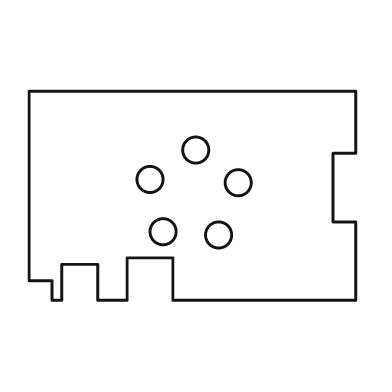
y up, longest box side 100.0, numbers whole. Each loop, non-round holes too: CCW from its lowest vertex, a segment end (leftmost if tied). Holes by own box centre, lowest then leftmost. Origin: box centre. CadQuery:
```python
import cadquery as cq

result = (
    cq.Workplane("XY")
    .moveTo(-43.0, -32.0)
    .lineTo(-40.0, -32.0)
    .lineTo(-40.0, -21.0)
    .lineTo(-29.0, -21.0)
    .lineTo(-29.0, -32.0)
    .lineTo(-20.0, -32.0)
    .lineTo(-20.0, -19.0)
    .lineTo(-6.0, -19.0)
    .lineTo(-6.0, -32.0)
    .lineTo(50.0, -32.0)
    .lineTo(50.0, -8.0)
    .lineTo(43.0, -8.0)
    .lineTo(43.0, 13.0)
    .lineTo(50.0, 13.0)
    .lineTo(50.0, 32.0)
    .lineTo(-50.0, 32.0)
    .lineTo(-50.0, -26.0)
    .lineTo(-43.0, -26.0)
    .close()
    .moveTo(8.0, -12.0)
    .circle(4.0)
    .moveTo(-9.0, -11.0)
    .circle(4.0)
    .moveTo(14.0, 4.0)
    .circle(4.0)
    .moveTo(-13.0, 5.0)
    .circle(4.0)
    .moveTo(1.0, 14.0)
    .circle(4.0)
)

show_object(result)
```